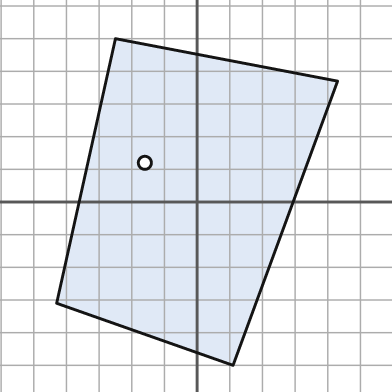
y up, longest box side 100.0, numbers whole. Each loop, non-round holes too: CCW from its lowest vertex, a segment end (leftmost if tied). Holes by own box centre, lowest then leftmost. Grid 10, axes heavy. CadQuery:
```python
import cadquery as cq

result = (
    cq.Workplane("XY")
    .moveTo(11.0, -50.0)
    .lineTo(43.0, 37.0)
    .lineTo(-25.0, 50.0)
    .lineTo(-43.0, -31.0)
    .close()
    .moveTo(-16.0, 12.0)
    .circle(2.0)
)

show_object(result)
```